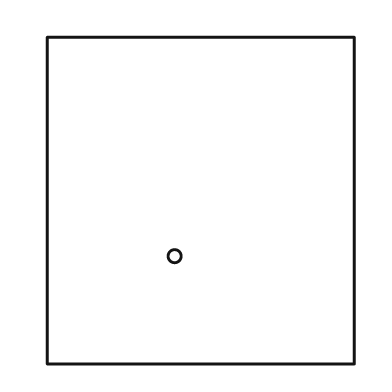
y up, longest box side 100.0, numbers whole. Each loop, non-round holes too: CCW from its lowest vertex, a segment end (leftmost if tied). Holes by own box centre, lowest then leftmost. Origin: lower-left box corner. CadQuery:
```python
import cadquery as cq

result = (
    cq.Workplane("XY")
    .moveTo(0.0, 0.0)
    .lineTo(94.0, 0.0)
    .lineTo(94.0, 100.0)
    .lineTo(0.0, 100.0)
    .close()
    .moveTo(39.0, 33.0)
    .circle(2.0)
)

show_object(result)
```